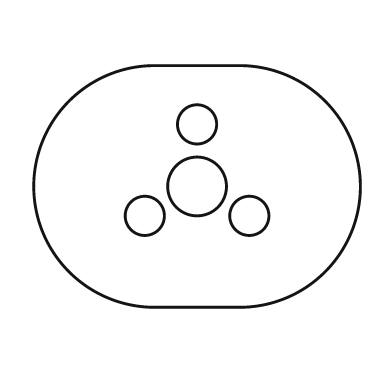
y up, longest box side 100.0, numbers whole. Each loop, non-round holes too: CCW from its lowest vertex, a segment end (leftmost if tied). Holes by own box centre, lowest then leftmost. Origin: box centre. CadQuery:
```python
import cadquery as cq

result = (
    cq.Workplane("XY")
    .moveTo(-13.0, -37.0)
    .lineTo(13.0, -37.0)
    .threePointArc((50.0, 0.0), (13.0, 37.0))
    .lineTo(-13.0, 37.0)
    .threePointArc((-50.0, 0.0), (-13.0, -37.0))
    .close()
    .moveTo(-16.0, -9.0)
    .circle(6.0)
    .moveTo(16.0, -9.0)
    .circle(6.0)
    .moveTo(0.0, 0.0)
    .circle(9.0)
    .moveTo(0.0, 19.0)
    .circle(6.0)
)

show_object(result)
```